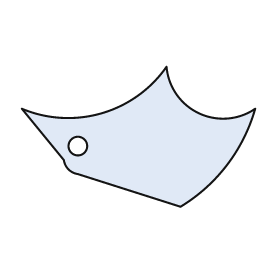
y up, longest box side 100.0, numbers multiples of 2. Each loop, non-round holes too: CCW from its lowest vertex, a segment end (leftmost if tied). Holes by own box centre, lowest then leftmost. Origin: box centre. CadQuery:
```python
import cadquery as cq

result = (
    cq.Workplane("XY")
    .moveTo(18.0, -30.0)
    .threePointArc((38.0, -12.0), (50.0, 12.0))
    .threePointArc((26.0, 10.0), (12.0, 30.0))
    .threePointArc((-16.0, 10.0), (-50.0, 12.0))
    .lineTo(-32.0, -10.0)
    .threePointArc((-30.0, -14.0), (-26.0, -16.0))
    .close()
    .moveTo(-26.0, -4.0)
    .circle(4.0)
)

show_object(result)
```